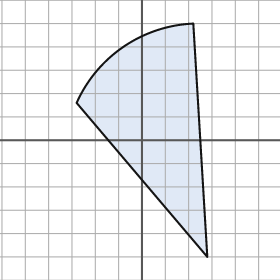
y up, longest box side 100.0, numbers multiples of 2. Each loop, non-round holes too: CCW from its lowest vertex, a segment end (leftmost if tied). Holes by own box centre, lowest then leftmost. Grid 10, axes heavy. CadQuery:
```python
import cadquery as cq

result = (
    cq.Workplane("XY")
    .moveTo(28.0, -50.0)
    .lineTo(22.0, 50.0)
    .threePointArc((-8.0, 40.0), (-28.0, 16.0))
    .close()
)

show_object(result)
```